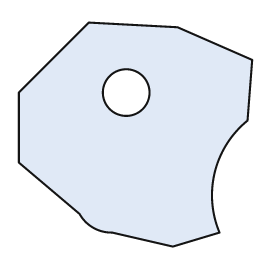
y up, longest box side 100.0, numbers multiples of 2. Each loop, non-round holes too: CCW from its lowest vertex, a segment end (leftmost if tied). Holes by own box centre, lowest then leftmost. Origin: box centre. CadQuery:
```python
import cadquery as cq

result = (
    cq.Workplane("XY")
    .moveTo(16.0, -48.0)
    .lineTo(36.0, -42.0)
    .threePointArc((34.0, -16.0), (48.0, 6.0))
    .lineTo(50.0, 32.0)
    .lineTo(18.0, 46.0)
    .lineTo(-20.0, 48.0)
    .lineTo(-50.0, 18.0)
    .lineTo(-50.0, -12.0)
    .lineTo(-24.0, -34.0)
    .threePointArc((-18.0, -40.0), (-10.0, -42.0))
    .close()
    .moveTo(-4.0, 18.0)
    .circle(10.0)
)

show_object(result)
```